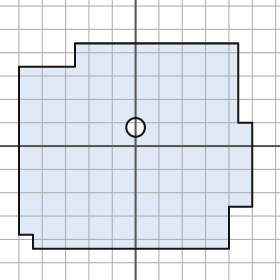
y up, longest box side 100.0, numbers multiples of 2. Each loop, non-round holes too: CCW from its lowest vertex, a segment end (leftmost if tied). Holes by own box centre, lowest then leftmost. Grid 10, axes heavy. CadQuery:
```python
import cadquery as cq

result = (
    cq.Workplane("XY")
    .moveTo(-44.0, -44.0)
    .lineTo(40.0, -44.0)
    .lineTo(40.0, -26.0)
    .lineTo(50.0, -26.0)
    .lineTo(50.0, 10.0)
    .lineTo(44.0, 10.0)
    .lineTo(44.0, 44.0)
    .lineTo(-26.0, 44.0)
    .lineTo(-26.0, 34.0)
    .lineTo(-50.0, 34.0)
    .lineTo(-50.0, -38.0)
    .lineTo(-44.0, -38.0)
    .close()
    .moveTo(0.0, 8.0)
    .circle(4.0)
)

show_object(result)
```